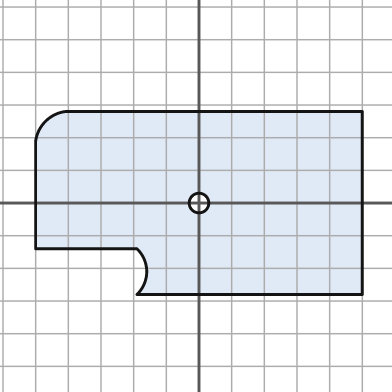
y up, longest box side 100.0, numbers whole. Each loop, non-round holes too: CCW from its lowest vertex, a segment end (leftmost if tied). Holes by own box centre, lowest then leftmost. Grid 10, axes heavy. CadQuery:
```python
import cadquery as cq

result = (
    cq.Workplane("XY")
    .moveTo(-19.0, -28.0)
    .lineTo(50.0, -28.0)
    .lineTo(50.0, 28.0)
    .lineTo(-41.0, 28.0)
    .threePointArc((-47.0, 25.0), (-50.0, 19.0))
    .lineTo(-50.0, -14.0)
    .lineTo(-19.0, -14.0)
    .threePointArc((-16.0, -21.0), (-19.0, -28.0))
    .close()
    .moveTo(0.0, 0.0)
    .circle(3.0)
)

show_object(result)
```